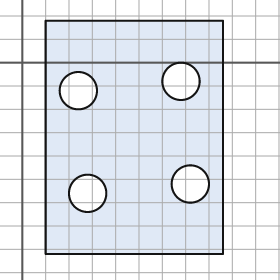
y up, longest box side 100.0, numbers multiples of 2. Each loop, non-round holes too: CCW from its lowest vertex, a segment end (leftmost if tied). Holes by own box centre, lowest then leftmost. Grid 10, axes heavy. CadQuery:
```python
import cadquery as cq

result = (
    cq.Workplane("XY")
    .moveTo(10.0, -82.0)
    .lineTo(86.0, -82.0)
    .lineTo(86.0, 18.0)
    .lineTo(10.0, 18.0)
    .close()
    .moveTo(28.0, -56.0)
    .circle(8.0)
    .moveTo(72.0, -52.0)
    .circle(8.0)
    .moveTo(24.0, -12.0)
    .circle(8.0)
    .moveTo(68.0, -8.0)
    .circle(8.0)
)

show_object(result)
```